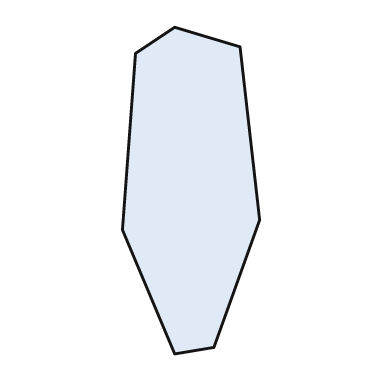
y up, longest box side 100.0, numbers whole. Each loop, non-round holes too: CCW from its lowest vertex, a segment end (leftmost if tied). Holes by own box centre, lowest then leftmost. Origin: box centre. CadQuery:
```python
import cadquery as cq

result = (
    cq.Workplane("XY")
    .moveTo(-5.0, -50.0)
    .lineTo(7.0, -48.0)
    .lineTo(21.0, -9.0)
    .lineTo(15.0, 44.0)
    .lineTo(-5.0, 50.0)
    .lineTo(-17.0, 42.0)
    .lineTo(-21.0, -12.0)
    .close()
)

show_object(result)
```